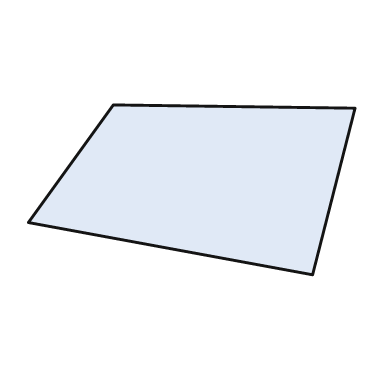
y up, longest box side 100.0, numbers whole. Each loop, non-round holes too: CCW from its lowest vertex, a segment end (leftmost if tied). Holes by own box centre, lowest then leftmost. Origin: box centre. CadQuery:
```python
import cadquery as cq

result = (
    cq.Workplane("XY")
    .moveTo(37.0, -26.0)
    .lineTo(50.0, 25.0)
    .lineTo(-24.0, 26.0)
    .lineTo(-50.0, -10.0)
    .close()
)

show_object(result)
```